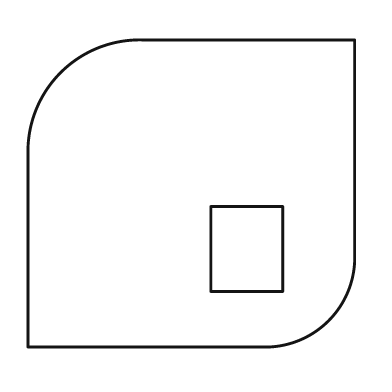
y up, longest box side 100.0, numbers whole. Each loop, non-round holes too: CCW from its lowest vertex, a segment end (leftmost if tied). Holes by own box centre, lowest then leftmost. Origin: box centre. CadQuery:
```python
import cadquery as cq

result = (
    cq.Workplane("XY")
    .moveTo(-50.0, -47.0)
    .lineTo(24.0, -47.0)
    .threePointArc((42.0, -39.0), (50.0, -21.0))
    .lineTo(50.0, 47.0)
    .lineTo(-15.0, 47.0)
    .threePointArc((-40.0, 37.0), (-50.0, 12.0))
    .close()
    .moveTo(6.0, -30.0)
    .lineTo(28.0, -30.0)
    .lineTo(28.0, -4.0)
    .lineTo(6.0, -4.0)
    .close()
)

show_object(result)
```